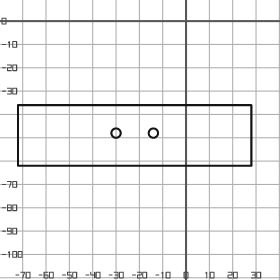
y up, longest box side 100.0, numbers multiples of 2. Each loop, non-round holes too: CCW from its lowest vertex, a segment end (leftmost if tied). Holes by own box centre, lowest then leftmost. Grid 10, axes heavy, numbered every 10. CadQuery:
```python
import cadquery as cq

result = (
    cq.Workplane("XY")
    .moveTo(-72.0, -62.0)
    .lineTo(28.0, -62.0)
    .lineTo(28.0, -36.0)
    .lineTo(-72.0, -36.0)
    .close()
    .moveTo(-30.0, -48.0)
    .circle(2.0)
    .moveTo(-14.0, -48.0)
    .circle(2.0)
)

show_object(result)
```